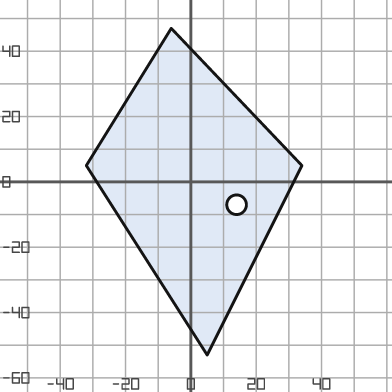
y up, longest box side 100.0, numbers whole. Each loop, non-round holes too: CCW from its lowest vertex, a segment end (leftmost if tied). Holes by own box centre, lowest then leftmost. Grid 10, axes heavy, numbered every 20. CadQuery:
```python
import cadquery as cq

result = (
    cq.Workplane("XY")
    .moveTo(5.0, -53.0)
    .lineTo(34.0, 5.0)
    .lineTo(-6.0, 47.0)
    .lineTo(-32.0, 5.0)
    .close()
    .moveTo(14.0, -7.0)
    .circle(3.0)
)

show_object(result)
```